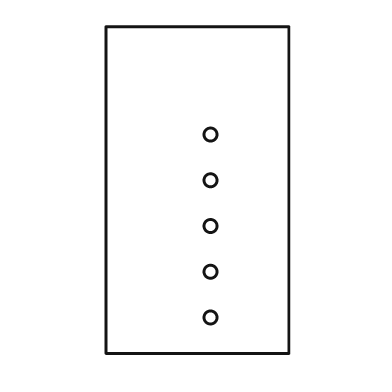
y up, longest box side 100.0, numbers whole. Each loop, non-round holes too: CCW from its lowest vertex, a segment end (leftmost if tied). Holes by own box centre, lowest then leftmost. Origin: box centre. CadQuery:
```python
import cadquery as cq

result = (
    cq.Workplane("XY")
    .moveTo(-28.0, -50.0)
    .lineTo(28.0, -50.0)
    .lineTo(28.0, 50.0)
    .lineTo(-28.0, 50.0)
    .close()
    .moveTo(4.0, -39.0)
    .circle(2.0)
    .moveTo(4.0, -25.0)
    .circle(2.0)
    .moveTo(4.0, -11.0)
    .circle(2.0)
    .moveTo(4.0, 3.0)
    .circle(2.0)
    .moveTo(4.0, 17.0)
    .circle(2.0)
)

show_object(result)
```